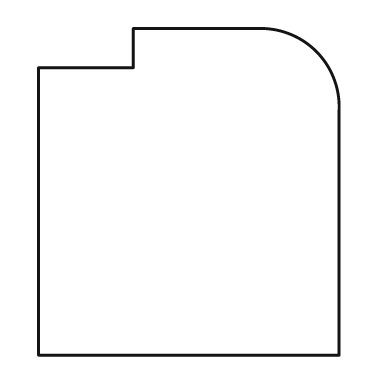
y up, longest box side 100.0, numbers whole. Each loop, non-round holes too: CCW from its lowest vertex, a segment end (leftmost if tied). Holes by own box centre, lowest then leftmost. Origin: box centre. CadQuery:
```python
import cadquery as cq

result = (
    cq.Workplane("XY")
    .moveTo(-46.0, -50.0)
    .lineTo(46.0, -50.0)
    .lineTo(46.0, 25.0)
    .threePointArc((39.0, 43.0), (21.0, 50.0))
    .lineTo(-17.0, 50.0)
    .lineTo(-17.0, 38.0)
    .lineTo(-46.0, 38.0)
    .close()
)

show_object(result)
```